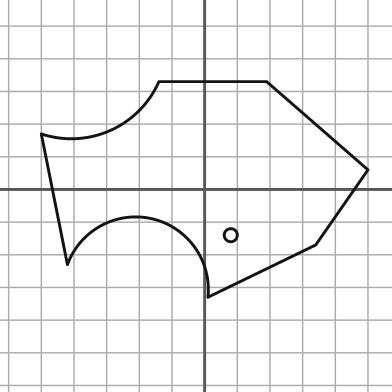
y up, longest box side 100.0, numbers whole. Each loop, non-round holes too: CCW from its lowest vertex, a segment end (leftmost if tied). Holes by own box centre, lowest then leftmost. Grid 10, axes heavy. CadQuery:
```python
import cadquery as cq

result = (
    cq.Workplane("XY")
    .moveTo(1.0, -33.0)
    .lineTo(34.0, -17.0)
    .lineTo(50.0, 6.0)
    .lineTo(19.0, 33.0)
    .lineTo(-14.0, 33.0)
    .threePointArc((-29.0, 18.0), (-50.0, 17.0))
    .lineTo(-42.0, -23.0)
    .threePointArc((-16.0, -9.0), (1.0, -33.0))
    .close()
    .moveTo(8.0, -14.0)
    .circle(2.0)
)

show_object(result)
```